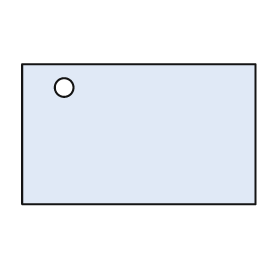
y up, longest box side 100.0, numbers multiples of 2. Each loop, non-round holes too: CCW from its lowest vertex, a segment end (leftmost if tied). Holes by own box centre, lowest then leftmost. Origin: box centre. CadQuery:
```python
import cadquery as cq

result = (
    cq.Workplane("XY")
    .moveTo(-50.0, -30.0)
    .lineTo(50.0, -30.0)
    .lineTo(50.0, 30.0)
    .lineTo(-50.0, 30.0)
    .close()
    .moveTo(-32.0, 20.0)
    .circle(4.0)
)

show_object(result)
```